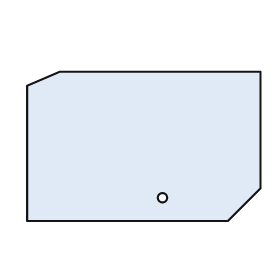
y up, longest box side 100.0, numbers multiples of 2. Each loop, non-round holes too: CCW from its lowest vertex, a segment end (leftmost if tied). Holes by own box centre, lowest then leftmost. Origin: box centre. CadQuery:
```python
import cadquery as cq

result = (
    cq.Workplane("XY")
    .moveTo(-50.0, -32.0)
    .lineTo(36.0, -32.0)
    .lineTo(50.0, -18.0)
    .lineTo(50.0, 32.0)
    .lineTo(-36.0, 32.0)
    .lineTo(-50.0, 26.0)
    .close()
    .moveTo(8.0, -22.0)
    .circle(2.0)
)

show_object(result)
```